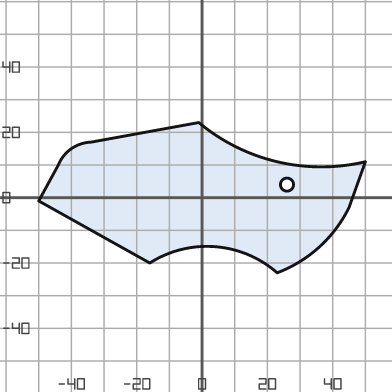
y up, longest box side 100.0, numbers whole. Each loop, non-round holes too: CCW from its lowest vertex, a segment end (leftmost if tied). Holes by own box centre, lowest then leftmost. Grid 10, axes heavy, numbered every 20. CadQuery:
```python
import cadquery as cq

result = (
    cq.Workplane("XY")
    .moveTo(23.0, -23.0)
    .threePointArc((36.0, -15.0), (45.0, -3.0))
    .lineTo(50.0, 11.0)
    .threePointArc((23.0, 11.0), (-1.0, 23.0))
    .lineTo(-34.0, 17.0)
    .threePointArc((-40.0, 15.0), (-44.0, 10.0))
    .lineTo(-50.0, -1.0)
    .lineTo(-16.0, -20.0)
    .threePointArc((4.0, -15.0), (23.0, -23.0))
    .close()
    .moveTo(26.0, 4.0)
    .circle(2.0)
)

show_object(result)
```